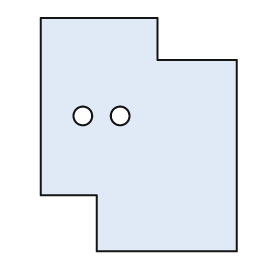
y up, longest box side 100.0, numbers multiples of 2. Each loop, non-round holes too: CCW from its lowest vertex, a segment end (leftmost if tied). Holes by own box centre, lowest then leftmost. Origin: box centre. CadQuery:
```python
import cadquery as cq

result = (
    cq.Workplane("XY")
    .moveTo(-18.0, -50.0)
    .lineTo(42.0, -50.0)
    .lineTo(42.0, 32.0)
    .lineTo(8.0, 32.0)
    .lineTo(8.0, 50.0)
    .lineTo(-42.0, 50.0)
    .lineTo(-42.0, -26.0)
    .lineTo(-18.0, -26.0)
    .close()
    .moveTo(-24.0, 8.0)
    .circle(4.0)
    .moveTo(-8.0, 8.0)
    .circle(4.0)
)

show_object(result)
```